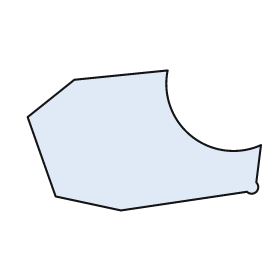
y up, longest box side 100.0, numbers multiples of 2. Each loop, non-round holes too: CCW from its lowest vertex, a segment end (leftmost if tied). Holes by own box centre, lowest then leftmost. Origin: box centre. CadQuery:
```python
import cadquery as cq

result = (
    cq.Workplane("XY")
    .moveTo(-10.0, -30.0)
    .lineTo(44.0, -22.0)
    .threePointArc((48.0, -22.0), (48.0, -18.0))
    .lineTo(50.0, -2.0)
    .threePointArc((20.0, 2.0), (10.0, 30.0))
    .lineTo(-30.0, 26.0)
    .lineTo(-50.0, 10.0)
    .lineTo(-38.0, -24.0)
    .close()
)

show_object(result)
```